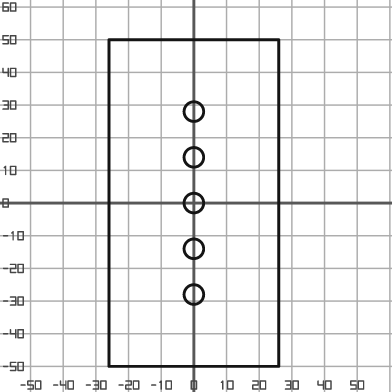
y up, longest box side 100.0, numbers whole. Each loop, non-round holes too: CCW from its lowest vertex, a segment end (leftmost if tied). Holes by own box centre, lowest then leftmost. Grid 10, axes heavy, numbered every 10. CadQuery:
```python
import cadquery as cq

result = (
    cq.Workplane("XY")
    .moveTo(-26.0, -50.0)
    .lineTo(26.0, -50.0)
    .lineTo(26.0, 50.0)
    .lineTo(-26.0, 50.0)
    .close()
    .moveTo(0.0, -28.0)
    .circle(3.0)
    .moveTo(0.0, -14.0)
    .circle(3.0)
    .moveTo(0.0, 0.0)
    .circle(3.0)
    .moveTo(0.0, 14.0)
    .circle(3.0)
    .moveTo(0.0, 28.0)
    .circle(3.0)
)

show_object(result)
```